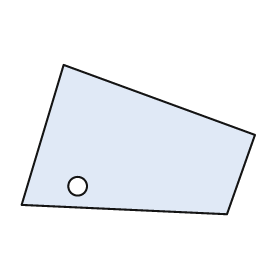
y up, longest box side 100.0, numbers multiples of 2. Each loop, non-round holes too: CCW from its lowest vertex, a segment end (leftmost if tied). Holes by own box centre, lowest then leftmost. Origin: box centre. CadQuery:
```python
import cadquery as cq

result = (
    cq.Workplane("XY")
    .moveTo(38.0, -32.0)
    .lineTo(50.0, 2.0)
    .lineTo(-32.0, 32.0)
    .lineTo(-50.0, -28.0)
    .close()
    .moveTo(-26.0, -20.0)
    .circle(4.0)
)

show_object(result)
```